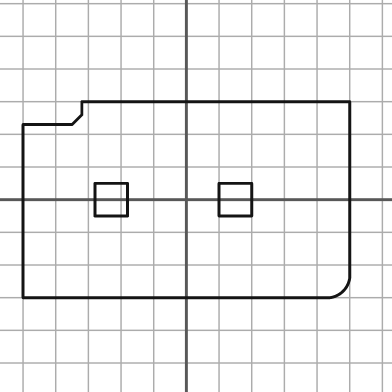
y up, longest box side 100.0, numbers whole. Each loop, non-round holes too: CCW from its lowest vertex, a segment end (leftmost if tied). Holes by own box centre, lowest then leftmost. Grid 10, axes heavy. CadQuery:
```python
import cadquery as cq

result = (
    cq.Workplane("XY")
    .moveTo(-50.0, -30.0)
    .lineTo(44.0, -30.0)
    .threePointArc((48.0, -28.0), (50.0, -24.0))
    .lineTo(50.0, 30.0)
    .lineTo(-32.0, 30.0)
    .lineTo(-32.0, 26.0)
    .lineTo(-35.0, 23.0)
    .lineTo(-50.0, 23.0)
    .close()
    .moveTo(-28.0, -5.0)
    .lineTo(-18.0, -5.0)
    .lineTo(-18.0, 5.0)
    .lineTo(-28.0, 5.0)
    .close()
    .moveTo(10.0, -5.0)
    .lineTo(20.0, -5.0)
    .lineTo(20.0, 5.0)
    .lineTo(10.0, 5.0)
    .close()
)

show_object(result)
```